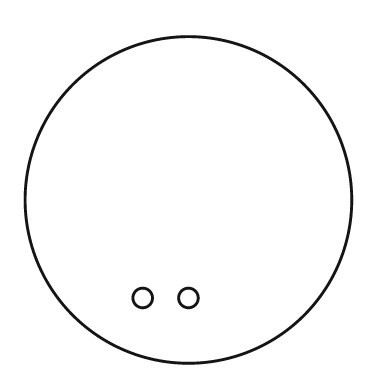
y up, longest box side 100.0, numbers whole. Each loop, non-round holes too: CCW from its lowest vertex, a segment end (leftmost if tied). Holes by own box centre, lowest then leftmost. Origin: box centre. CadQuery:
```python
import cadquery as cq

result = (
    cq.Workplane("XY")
    .moveTo(0.0, 0.0)
    .circle(50.0)
    .moveTo(-14.0, -30.0)
    .circle(3.0)
    .moveTo(0.0, -30.0)
    .circle(3.0)
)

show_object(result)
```